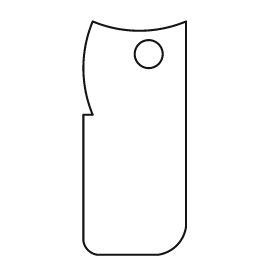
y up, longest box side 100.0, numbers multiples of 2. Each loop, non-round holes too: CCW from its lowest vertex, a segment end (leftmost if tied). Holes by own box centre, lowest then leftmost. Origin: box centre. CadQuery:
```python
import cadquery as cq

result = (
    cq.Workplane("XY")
    .moveTo(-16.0, -50.0)
    .lineTo(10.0, -50.0)
    .threePointArc((18.0, -46.0), (22.0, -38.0))
    .lineTo(22.0, 50.0)
    .threePointArc((2.0, 46.0), (-18.0, 50.0))
    .threePointArc((-22.0, 30.0), (-18.0, 10.0))
    .lineTo(-22.0, 10.0)
    .lineTo(-22.0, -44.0)
    .threePointArc((-20.0, -48.0), (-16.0, -50.0))
    .close()
    .moveTo(6.0, 36.0)
    .circle(6.0)
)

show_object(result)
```